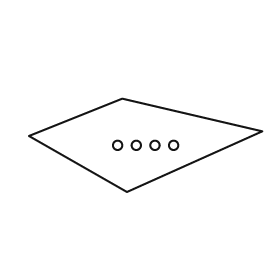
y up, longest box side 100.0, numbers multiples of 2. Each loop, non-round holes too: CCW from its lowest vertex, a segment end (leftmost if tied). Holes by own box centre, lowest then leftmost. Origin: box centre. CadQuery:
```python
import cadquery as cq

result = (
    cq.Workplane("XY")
    .moveTo(-8.0, -20.0)
    .lineTo(50.0, 6.0)
    .lineTo(-10.0, 20.0)
    .lineTo(-50.0, 4.0)
    .close()
    .moveTo(-12.0, 0.0)
    .circle(2.0)
    .moveTo(-4.0, 0.0)
    .circle(2.0)
    .moveTo(4.0, 0.0)
    .circle(2.0)
    .moveTo(12.0, 0.0)
    .circle(2.0)
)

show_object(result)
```